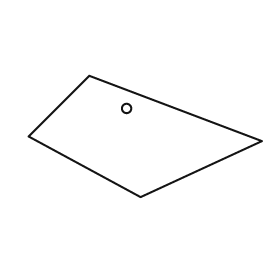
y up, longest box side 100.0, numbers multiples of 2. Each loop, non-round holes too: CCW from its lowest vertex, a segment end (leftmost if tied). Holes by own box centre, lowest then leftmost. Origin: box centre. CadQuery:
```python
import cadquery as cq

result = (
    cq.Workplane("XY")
    .moveTo(-2.0, -26.0)
    .lineTo(50.0, -2.0)
    .lineTo(-24.0, 26.0)
    .lineTo(-50.0, 0.0)
    .close()
    .moveTo(-8.0, 12.0)
    .circle(2.0)
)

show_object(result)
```